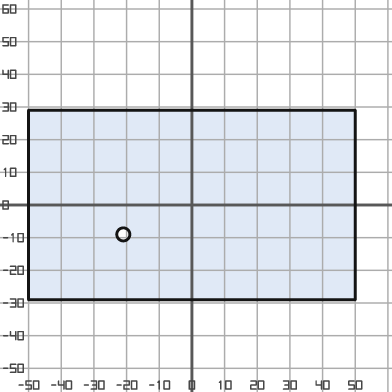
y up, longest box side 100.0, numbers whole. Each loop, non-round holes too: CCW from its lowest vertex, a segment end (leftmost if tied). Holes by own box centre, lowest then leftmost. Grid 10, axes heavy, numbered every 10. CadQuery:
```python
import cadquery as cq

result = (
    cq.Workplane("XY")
    .moveTo(-50.0, -29.0)
    .lineTo(50.0, -29.0)
    .lineTo(50.0, 29.0)
    .lineTo(-50.0, 29.0)
    .close()
    .moveTo(-21.0, -9.0)
    .circle(2.0)
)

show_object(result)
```